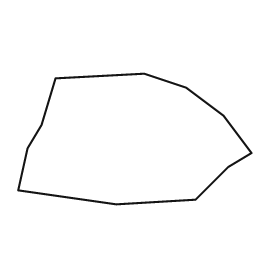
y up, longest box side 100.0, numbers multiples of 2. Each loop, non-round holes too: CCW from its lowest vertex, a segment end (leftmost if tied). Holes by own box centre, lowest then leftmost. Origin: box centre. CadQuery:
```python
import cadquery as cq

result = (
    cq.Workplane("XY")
    .moveTo(-8.0, -28.0)
    .lineTo(26.0, -26.0)
    .lineTo(40.0, -12.0)
    .lineTo(50.0, -6.0)
    .lineTo(38.0, 10.0)
    .lineTo(22.0, 22.0)
    .lineTo(4.0, 28.0)
    .lineTo(-34.0, 26.0)
    .lineTo(-40.0, 6.0)
    .lineTo(-46.0, -4.0)
    .lineTo(-50.0, -22.0)
    .close()
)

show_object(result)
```